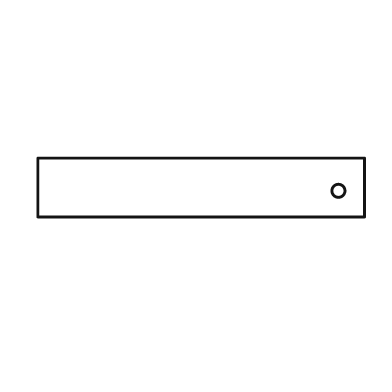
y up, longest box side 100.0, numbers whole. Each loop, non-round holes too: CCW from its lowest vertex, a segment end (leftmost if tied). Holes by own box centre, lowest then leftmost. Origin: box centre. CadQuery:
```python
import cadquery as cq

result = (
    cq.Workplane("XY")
    .moveTo(-50.0, -9.0)
    .lineTo(50.0, -9.0)
    .lineTo(50.0, 9.0)
    .lineTo(-50.0, 9.0)
    .close()
    .moveTo(42.0, -1.0)
    .circle(2.0)
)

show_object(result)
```